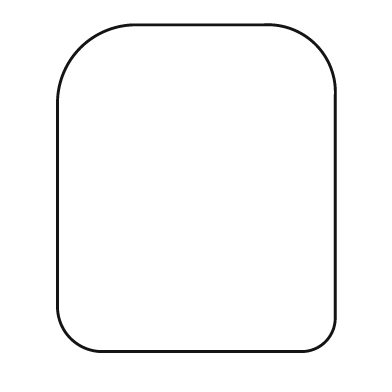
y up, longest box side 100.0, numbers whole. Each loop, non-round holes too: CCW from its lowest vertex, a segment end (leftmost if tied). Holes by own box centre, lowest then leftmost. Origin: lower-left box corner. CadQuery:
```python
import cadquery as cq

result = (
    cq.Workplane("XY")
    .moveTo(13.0, 0.0)
    .lineTo(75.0, 0.0)
    .threePointArc((82.0, 3.0), (85.0, 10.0))
    .lineTo(85.0, 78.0)
    .threePointArc((79.0, 94.0), (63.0, 100.0))
    .lineTo(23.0, 100.0)
    .threePointArc((7.0, 93.0), (0.0, 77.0))
    .lineTo(0.0, 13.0)
    .threePointArc((4.0, 4.0), (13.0, 0.0))
    .close()
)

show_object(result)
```